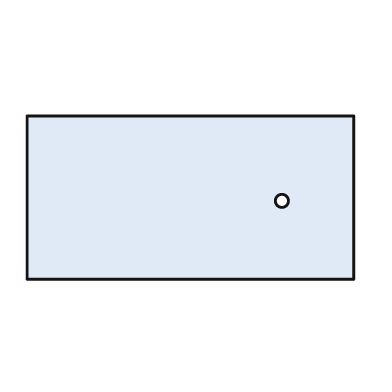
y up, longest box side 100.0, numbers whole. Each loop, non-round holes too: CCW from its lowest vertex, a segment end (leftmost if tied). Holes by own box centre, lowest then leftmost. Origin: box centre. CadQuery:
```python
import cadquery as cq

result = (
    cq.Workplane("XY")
    .moveTo(-50.0, -25.0)
    .lineTo(50.0, -25.0)
    .lineTo(50.0, 25.0)
    .lineTo(-50.0, 25.0)
    .close()
    .moveTo(28.0, -1.0)
    .circle(2.0)
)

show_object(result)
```